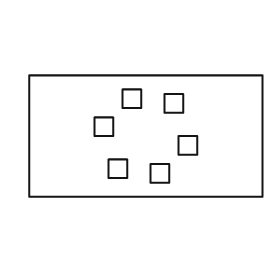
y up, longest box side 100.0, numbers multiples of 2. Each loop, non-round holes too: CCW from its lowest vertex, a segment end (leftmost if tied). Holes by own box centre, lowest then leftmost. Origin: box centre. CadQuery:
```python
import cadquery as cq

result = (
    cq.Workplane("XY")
    .moveTo(-50.0, -26.0)
    .lineTo(50.0, -26.0)
    .lineTo(50.0, 26.0)
    .lineTo(-50.0, 26.0)
    .close()
    .moveTo(2.0, -20.0)
    .lineTo(10.0, -20.0)
    .lineTo(10.0, -12.0)
    .lineTo(2.0, -12.0)
    .close()
    .moveTo(-16.0, -18.0)
    .lineTo(-8.0, -18.0)
    .lineTo(-8.0, -10.0)
    .lineTo(-16.0, -10.0)
    .close()
    .moveTo(14.0, -8.0)
    .lineTo(22.0, -8.0)
    .lineTo(22.0, 0.0)
    .lineTo(14.0, 0.0)
    .close()
    .moveTo(-22.0, 0.0)
    .lineTo(-14.0, 0.0)
    .lineTo(-14.0, 8.0)
    .lineTo(-22.0, 8.0)
    .close()
    .moveTo(8.0, 10.0)
    .lineTo(16.0, 10.0)
    .lineTo(16.0, 18.0)
    .lineTo(8.0, 18.0)
    .close()
    .moveTo(-10.0, 12.0)
    .lineTo(-2.0, 12.0)
    .lineTo(-2.0, 20.0)
    .lineTo(-10.0, 20.0)
    .close()
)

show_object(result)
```